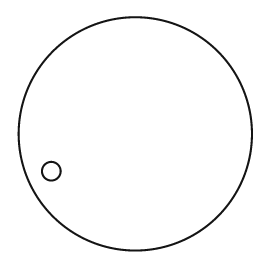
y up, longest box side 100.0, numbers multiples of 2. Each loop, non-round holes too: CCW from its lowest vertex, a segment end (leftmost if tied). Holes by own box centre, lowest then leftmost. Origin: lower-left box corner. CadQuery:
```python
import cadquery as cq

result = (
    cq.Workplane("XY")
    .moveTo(50.0, 50.0)
    .circle(50.0)
    .moveTo(14.0, 34.0)
    .circle(4.0)
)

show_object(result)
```